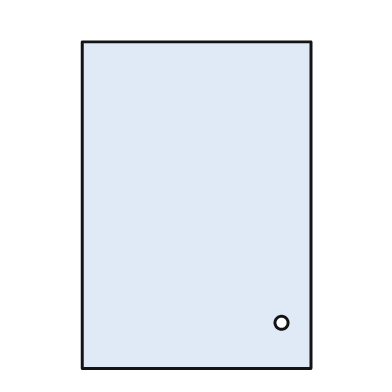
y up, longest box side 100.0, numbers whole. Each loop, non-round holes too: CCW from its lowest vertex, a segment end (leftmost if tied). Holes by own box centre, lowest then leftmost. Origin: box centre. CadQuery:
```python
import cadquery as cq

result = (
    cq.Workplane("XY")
    .moveTo(-35.0, -50.0)
    .lineTo(35.0, -50.0)
    .lineTo(35.0, 50.0)
    .lineTo(-35.0, 50.0)
    .close()
    .moveTo(26.0, -36.0)
    .circle(2.0)
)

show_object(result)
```